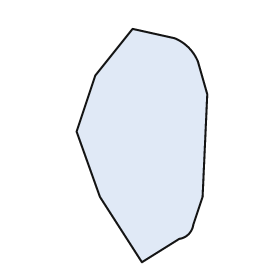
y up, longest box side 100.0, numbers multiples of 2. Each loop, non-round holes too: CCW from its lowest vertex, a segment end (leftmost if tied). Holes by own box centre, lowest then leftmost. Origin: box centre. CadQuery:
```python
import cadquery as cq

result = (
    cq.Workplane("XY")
    .moveTo(0.0, -50.0)
    .lineTo(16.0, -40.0)
    .threePointArc((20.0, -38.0), (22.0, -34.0))
    .lineTo(26.0, -22.0)
    .lineTo(28.0, 22.0)
    .lineTo(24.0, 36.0)
    .threePointArc((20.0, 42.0), (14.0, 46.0))
    .lineTo(-4.0, 50.0)
    .lineTo(-20.0, 30.0)
    .lineTo(-28.0, 6.0)
    .lineTo(-18.0, -22.0)
    .close()
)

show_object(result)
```